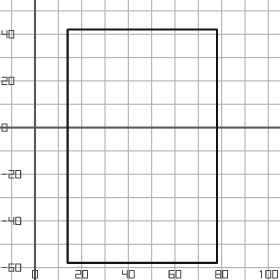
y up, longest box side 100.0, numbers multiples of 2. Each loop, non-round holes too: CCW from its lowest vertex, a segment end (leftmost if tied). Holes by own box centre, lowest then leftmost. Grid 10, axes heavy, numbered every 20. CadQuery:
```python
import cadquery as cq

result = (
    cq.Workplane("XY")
    .moveTo(14.0, -58.0)
    .lineTo(78.0, -58.0)
    .lineTo(78.0, 42.0)
    .lineTo(14.0, 42.0)
    .close()
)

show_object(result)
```